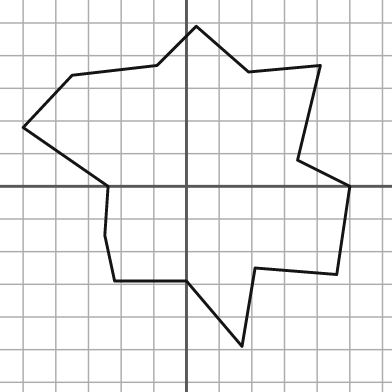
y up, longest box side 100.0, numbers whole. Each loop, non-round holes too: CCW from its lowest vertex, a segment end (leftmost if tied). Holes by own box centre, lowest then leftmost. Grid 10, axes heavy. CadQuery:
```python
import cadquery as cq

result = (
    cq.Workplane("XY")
    .moveTo(17.0, -49.0)
    .lineTo(21.0, -25.0)
    .lineTo(46.0, -27.0)
    .lineTo(50.0, 0.0)
    .lineTo(34.0, 8.0)
    .lineTo(41.0, 37.0)
    .lineTo(19.0, 35.0)
    .lineTo(3.0, 49.0)
    .lineTo(-9.0, 37.0)
    .lineTo(-35.0, 34.0)
    .lineTo(-50.0, 18.0)
    .lineTo(-24.0, 0.0)
    .lineTo(-25.0, -15.0)
    .lineTo(-22.0, -29.0)
    .lineTo(0.0, -29.0)
    .close()
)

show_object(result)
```